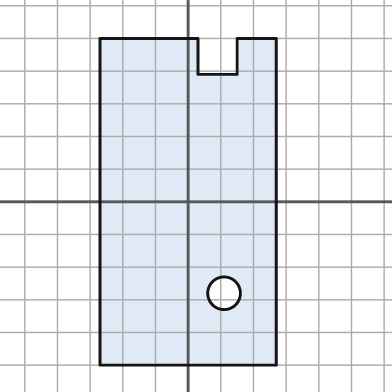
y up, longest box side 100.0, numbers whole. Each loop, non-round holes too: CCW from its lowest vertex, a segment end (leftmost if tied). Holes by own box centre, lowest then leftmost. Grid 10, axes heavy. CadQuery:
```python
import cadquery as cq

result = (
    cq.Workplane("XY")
    .moveTo(-27.0, -50.0)
    .lineTo(27.0, -50.0)
    .lineTo(27.0, 50.0)
    .lineTo(15.0, 50.0)
    .lineTo(15.0, 39.0)
    .lineTo(3.0, 39.0)
    .lineTo(3.0, 50.0)
    .lineTo(-27.0, 50.0)
    .close()
    .moveTo(11.0, -28.0)
    .circle(5.0)
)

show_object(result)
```